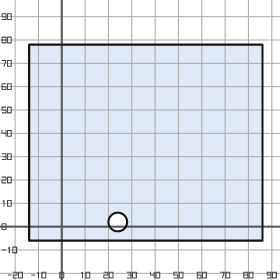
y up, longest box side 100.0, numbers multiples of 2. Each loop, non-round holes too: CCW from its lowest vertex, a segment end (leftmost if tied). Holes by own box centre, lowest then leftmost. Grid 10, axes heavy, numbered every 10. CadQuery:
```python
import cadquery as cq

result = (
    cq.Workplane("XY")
    .moveTo(-14.0, -6.0)
    .lineTo(86.0, -6.0)
    .lineTo(86.0, 78.0)
    .lineTo(-14.0, 78.0)
    .close()
    .moveTo(24.0, 2.0)
    .circle(4.0)
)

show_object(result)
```